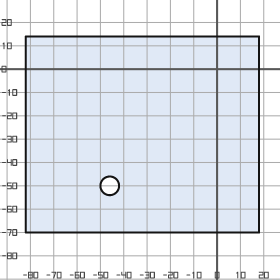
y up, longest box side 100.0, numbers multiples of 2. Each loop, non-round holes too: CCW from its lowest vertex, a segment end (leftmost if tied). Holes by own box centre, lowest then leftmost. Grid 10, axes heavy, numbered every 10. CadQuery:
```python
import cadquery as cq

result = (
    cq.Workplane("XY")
    .moveTo(-82.0, -70.0)
    .lineTo(18.0, -70.0)
    .lineTo(18.0, 14.0)
    .lineTo(-82.0, 14.0)
    .close()
    .moveTo(-46.0, -50.0)
    .circle(4.0)
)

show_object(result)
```